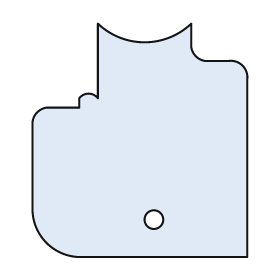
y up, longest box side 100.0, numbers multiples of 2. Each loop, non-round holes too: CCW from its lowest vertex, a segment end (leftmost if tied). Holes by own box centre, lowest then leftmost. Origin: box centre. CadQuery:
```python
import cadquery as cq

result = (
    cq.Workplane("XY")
    .moveTo(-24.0, -50.0)
    .lineTo(46.0, -50.0)
    .lineTo(46.0, 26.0)
    .threePointArc((44.0, 32.0), (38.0, 34.0))
    .lineTo(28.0, 34.0)
    .threePointArc((24.0, 36.0), (22.0, 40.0))
    .lineTo(22.0, 50.0)
    .threePointArc((2.0, 42.0), (-18.0, 50.0))
    .lineTo(-18.0, 18.0)
    .threePointArc((-22.0, 20.0), (-26.0, 18.0))
    .lineTo(-26.0, 14.0)
    .lineTo(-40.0, 14.0)
    .threePointArc((-44.0, 12.0), (-46.0, 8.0))
    .lineTo(-46.0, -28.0)
    .threePointArc((-40.0, -44.0), (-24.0, -50.0))
    .close()
    .moveTo(6.0, -34.0)
    .circle(4.0)
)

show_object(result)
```